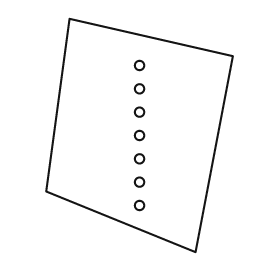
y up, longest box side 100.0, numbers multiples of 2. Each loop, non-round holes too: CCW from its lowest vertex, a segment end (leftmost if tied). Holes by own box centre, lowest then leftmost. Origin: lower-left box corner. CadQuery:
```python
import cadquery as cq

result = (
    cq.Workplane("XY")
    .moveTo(64.0, 0.0)
    .lineTo(80.0, 84.0)
    .lineTo(10.0, 100.0)
    .lineTo(0.0, 26.0)
    .close()
    .moveTo(40.0, 20.0)
    .circle(2.0)
    .moveTo(40.0, 30.0)
    .circle(2.0)
    .moveTo(40.0, 40.0)
    .circle(2.0)
    .moveTo(40.0, 50.0)
    .circle(2.0)
    .moveTo(40.0, 60.0)
    .circle(2.0)
    .moveTo(40.0, 70.0)
    .circle(2.0)
    .moveTo(40.0, 80.0)
    .circle(2.0)
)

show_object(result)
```